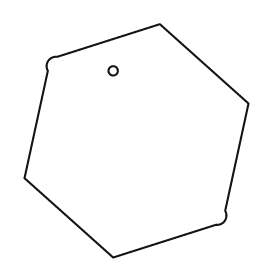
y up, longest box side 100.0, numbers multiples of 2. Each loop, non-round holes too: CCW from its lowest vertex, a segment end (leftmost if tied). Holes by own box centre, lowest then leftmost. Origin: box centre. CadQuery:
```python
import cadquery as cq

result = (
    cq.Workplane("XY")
    .moveTo(-10.0, -50.0)
    .lineTo(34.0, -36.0)
    .threePointArc((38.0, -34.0), (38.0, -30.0))
    .lineTo(48.0, 16.0)
    .lineTo(10.0, 50.0)
    .lineTo(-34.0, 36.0)
    .threePointArc((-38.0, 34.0), (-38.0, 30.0))
    .lineTo(-48.0, -16.0)
    .close()
    .moveTo(-10.0, 30.0)
    .circle(2.0)
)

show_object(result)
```